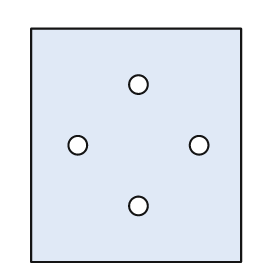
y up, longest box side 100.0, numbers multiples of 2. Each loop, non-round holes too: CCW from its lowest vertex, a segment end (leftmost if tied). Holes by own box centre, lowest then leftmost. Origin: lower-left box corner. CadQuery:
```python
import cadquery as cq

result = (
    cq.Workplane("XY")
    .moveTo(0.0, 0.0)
    .lineTo(90.0, 0.0)
    .lineTo(90.0, 100.0)
    .lineTo(0.0, 100.0)
    .close()
    .moveTo(46.0, 24.0)
    .circle(4.0)
    .moveTo(20.0, 50.0)
    .circle(4.0)
    .moveTo(72.0, 50.0)
    .circle(4.0)
    .moveTo(46.0, 76.0)
    .circle(4.0)
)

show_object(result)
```